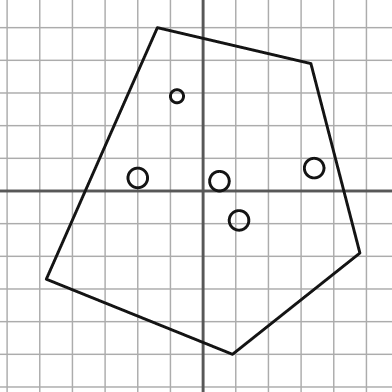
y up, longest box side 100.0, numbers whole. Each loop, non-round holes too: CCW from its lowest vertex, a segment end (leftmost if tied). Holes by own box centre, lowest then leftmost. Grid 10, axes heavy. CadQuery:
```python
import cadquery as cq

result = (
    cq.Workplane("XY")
    .moveTo(9.0, -50.0)
    .lineTo(48.0, -19.0)
    .lineTo(33.0, 39.0)
    .lineTo(-14.0, 50.0)
    .lineTo(-48.0, -27.0)
    .close()
    .moveTo(11.0, -9.0)
    .circle(3.0)
    .moveTo(5.0, 3.0)
    .circle(3.0)
    .moveTo(-20.0, 4.0)
    .circle(3.0)
    .moveTo(34.0, 7.0)
    .circle(3.0)
    .moveTo(-8.0, 29.0)
    .circle(2.0)
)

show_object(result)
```